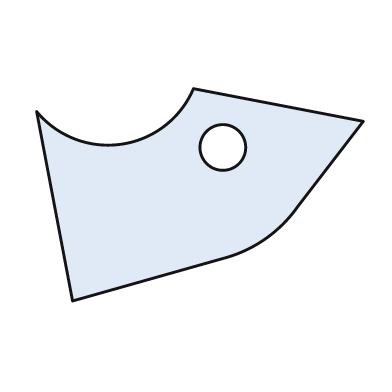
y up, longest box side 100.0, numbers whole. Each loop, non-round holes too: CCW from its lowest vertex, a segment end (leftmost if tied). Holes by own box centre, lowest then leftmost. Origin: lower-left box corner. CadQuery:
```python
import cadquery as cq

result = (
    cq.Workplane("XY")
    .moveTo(11.0, 0.0)
    .lineTo(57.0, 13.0)
    .threePointArc((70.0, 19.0), (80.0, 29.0))
    .lineTo(100.0, 55.0)
    .lineTo(48.0, 65.0)
    .threePointArc((26.0, 48.0), (0.0, 58.0))
    .close()
    .moveTo(57.0, 47.0)
    .circle(7.0)
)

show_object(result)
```